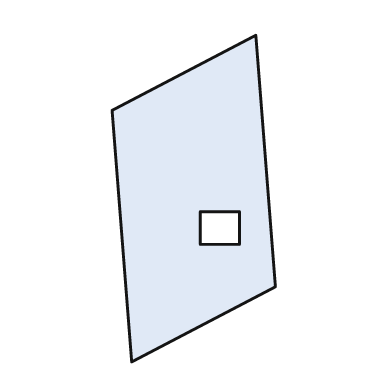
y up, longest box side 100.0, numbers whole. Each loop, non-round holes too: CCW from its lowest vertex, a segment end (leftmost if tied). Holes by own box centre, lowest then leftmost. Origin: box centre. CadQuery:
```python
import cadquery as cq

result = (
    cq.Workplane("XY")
    .moveTo(-19.0, -50.0)
    .lineTo(25.0, -27.0)
    .lineTo(19.0, 50.0)
    .lineTo(-25.0, 27.0)
    .close()
    .moveTo(2.0, -14.0)
    .lineTo(14.0, -14.0)
    .lineTo(14.0, -4.0)
    .lineTo(2.0, -4.0)
    .close()
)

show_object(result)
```